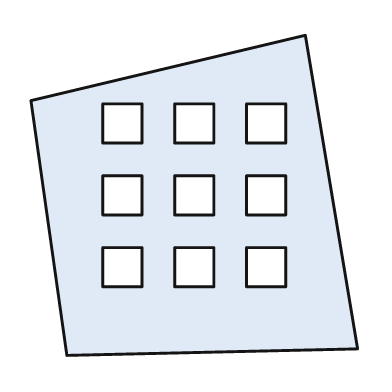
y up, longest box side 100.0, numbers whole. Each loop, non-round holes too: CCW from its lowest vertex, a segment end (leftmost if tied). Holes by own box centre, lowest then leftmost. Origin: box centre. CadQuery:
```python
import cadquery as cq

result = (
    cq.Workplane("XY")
    .moveTo(-39.0, -49.0)
    .lineTo(50.0, -47.0)
    .lineTo(34.0, 49.0)
    .lineTo(-50.0, 29.0)
    .close()
    .moveTo(-28.0, -28.0)
    .lineTo(-16.0, -28.0)
    .lineTo(-16.0, -16.0)
    .lineTo(-28.0, -16.0)
    .close()
    .moveTo(-6.0, -28.0)
    .lineTo(6.0, -28.0)
    .lineTo(6.0, -16.0)
    .lineTo(-6.0, -16.0)
    .close()
    .moveTo(16.0, -28.0)
    .lineTo(28.0, -28.0)
    .lineTo(28.0, -16.0)
    .lineTo(16.0, -16.0)
    .close()
    .moveTo(-28.0, -6.0)
    .lineTo(-16.0, -6.0)
    .lineTo(-16.0, 6.0)
    .lineTo(-28.0, 6.0)
    .close()
    .moveTo(-6.0, -6.0)
    .lineTo(6.0, -6.0)
    .lineTo(6.0, 6.0)
    .lineTo(-6.0, 6.0)
    .close()
    .moveTo(16.0, -6.0)
    .lineTo(28.0, -6.0)
    .lineTo(28.0, 6.0)
    .lineTo(16.0, 6.0)
    .close()
    .moveTo(-28.0, 16.0)
    .lineTo(-16.0, 16.0)
    .lineTo(-16.0, 28.0)
    .lineTo(-28.0, 28.0)
    .close()
    .moveTo(-6.0, 16.0)
    .lineTo(6.0, 16.0)
    .lineTo(6.0, 28.0)
    .lineTo(-6.0, 28.0)
    .close()
    .moveTo(16.0, 16.0)
    .lineTo(28.0, 16.0)
    .lineTo(28.0, 28.0)
    .lineTo(16.0, 28.0)
    .close()
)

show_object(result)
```